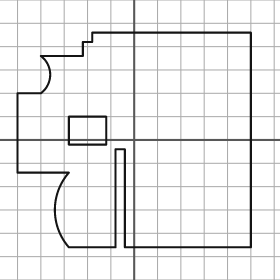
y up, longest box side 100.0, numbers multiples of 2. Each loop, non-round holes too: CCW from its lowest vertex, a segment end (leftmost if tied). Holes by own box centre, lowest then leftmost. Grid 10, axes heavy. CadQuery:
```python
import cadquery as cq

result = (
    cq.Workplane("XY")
    .moveTo(-28.0, -46.0)
    .lineTo(-8.0, -46.0)
    .lineTo(-8.0, -4.0)
    .lineTo(-4.0, -4.0)
    .lineTo(-4.0, -46.0)
    .lineTo(50.0, -46.0)
    .lineTo(50.0, 46.0)
    .lineTo(-18.0, 46.0)
    .lineTo(-18.0, 42.0)
    .lineTo(-22.0, 42.0)
    .lineTo(-22.0, 36.0)
    .lineTo(-40.0, 36.0)
    .threePointArc((-36.0, 28.0), (-40.0, 20.0))
    .lineTo(-50.0, 20.0)
    .lineTo(-50.0, -14.0)
    .lineTo(-28.0, -14.0)
    .threePointArc((-34.0, -30.0), (-28.0, -46.0))
    .close()
    .moveTo(-28.0, -2.0)
    .lineTo(-12.0, -2.0)
    .lineTo(-12.0, 10.0)
    .lineTo(-28.0, 10.0)
    .close()
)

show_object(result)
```